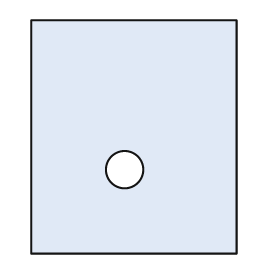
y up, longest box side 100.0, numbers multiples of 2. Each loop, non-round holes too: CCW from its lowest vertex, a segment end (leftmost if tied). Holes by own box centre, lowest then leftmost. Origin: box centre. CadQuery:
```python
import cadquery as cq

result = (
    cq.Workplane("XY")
    .moveTo(-44.0, -50.0)
    .lineTo(44.0, -50.0)
    .lineTo(44.0, 50.0)
    .lineTo(-44.0, 50.0)
    .close()
    .moveTo(-4.0, -14.0)
    .circle(8.0)
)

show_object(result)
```